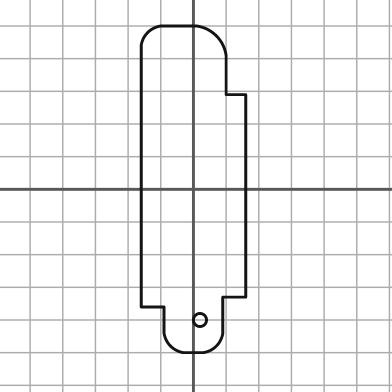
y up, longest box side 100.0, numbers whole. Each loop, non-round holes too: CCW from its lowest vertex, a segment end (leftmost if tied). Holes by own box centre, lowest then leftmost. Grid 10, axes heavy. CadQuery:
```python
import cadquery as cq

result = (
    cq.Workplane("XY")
    .moveTo(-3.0, -50.0)
    .lineTo(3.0, -50.0)
    .threePointArc((7.0, -48.0), (9.0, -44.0))
    .lineTo(9.0, -33.0)
    .lineTo(16.0, -33.0)
    .lineTo(16.0, 29.0)
    .lineTo(10.0, 29.0)
    .lineTo(10.0, 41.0)
    .threePointArc((7.0, 47.0), (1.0, 50.0))
    .lineTo(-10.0, 50.0)
    .threePointArc((-14.0, 48.0), (-16.0, 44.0))
    .lineTo(-16.0, -36.0)
    .lineTo(-9.0, -36.0)
    .lineTo(-9.0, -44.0)
    .threePointArc((-7.0, -48.0), (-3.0, -50.0))
    .close()
    .moveTo(2.0, -40.0)
    .circle(2.0)
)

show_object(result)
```